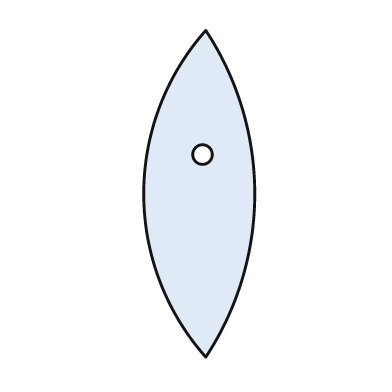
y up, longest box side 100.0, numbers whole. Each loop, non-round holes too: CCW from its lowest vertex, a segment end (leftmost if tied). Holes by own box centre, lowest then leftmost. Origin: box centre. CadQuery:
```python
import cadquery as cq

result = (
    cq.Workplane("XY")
    .moveTo(2.0, -50.0)
    .threePointArc((17.0, 0.0), (2.0, 50.0))
    .threePointArc((-17.0, 0.0), (2.0, -50.0))
    .close()
    .moveTo(1.0, 12.0)
    .circle(3.0)
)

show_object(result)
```